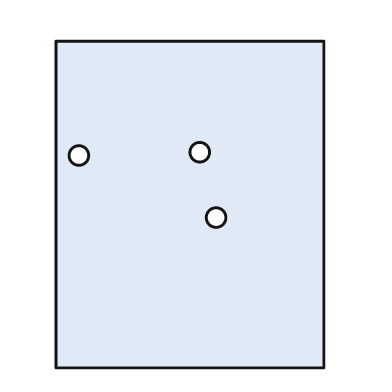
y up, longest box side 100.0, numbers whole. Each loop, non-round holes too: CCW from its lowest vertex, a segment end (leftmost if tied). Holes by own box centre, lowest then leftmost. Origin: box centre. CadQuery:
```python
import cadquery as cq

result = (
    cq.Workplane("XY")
    .moveTo(-41.0, -50.0)
    .lineTo(41.0, -50.0)
    .lineTo(41.0, 50.0)
    .lineTo(-41.0, 50.0)
    .close()
    .moveTo(8.0, -4.0)
    .circle(3.0)
    .moveTo(-34.0, 15.0)
    .circle(3.0)
    .moveTo(3.0, 16.0)
    .circle(3.0)
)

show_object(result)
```